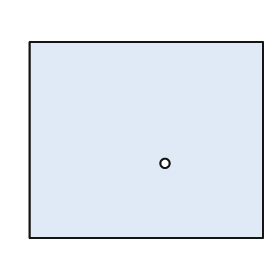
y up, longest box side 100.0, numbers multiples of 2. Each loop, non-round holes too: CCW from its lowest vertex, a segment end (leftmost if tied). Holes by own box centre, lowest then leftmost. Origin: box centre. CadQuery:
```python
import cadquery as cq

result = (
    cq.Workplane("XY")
    .moveTo(-50.0, -42.0)
    .lineTo(50.0, -42.0)
    .lineTo(50.0, 42.0)
    .lineTo(-50.0, 42.0)
    .close()
    .moveTo(8.0, -10.0)
    .circle(2.0)
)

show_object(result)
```